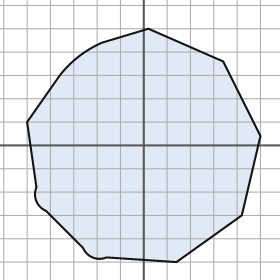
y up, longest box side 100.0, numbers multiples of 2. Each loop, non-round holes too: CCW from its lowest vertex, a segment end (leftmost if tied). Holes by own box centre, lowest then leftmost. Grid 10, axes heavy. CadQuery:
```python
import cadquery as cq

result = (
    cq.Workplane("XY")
    .moveTo(14.0, -50.0)
    .lineTo(42.0, -30.0)
    .lineTo(50.0, 4.0)
    .lineTo(34.0, 36.0)
    .lineTo(2.0, 50.0)
    .lineTo(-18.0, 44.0)
    .threePointArc((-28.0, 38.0), (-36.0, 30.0))
    .lineTo(-50.0, 10.0)
    .lineTo(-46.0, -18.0)
    .threePointArc((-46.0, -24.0), (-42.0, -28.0))
    .lineTo(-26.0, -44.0)
    .threePointArc((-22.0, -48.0), (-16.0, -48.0))
    .close()
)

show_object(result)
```